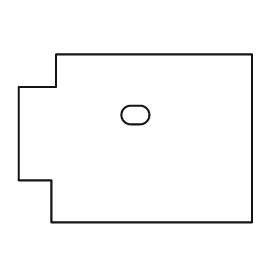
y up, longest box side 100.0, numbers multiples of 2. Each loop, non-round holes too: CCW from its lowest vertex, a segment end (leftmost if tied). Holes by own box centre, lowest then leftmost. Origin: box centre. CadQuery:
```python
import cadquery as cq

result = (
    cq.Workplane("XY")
    .moveTo(-36.0, -36.0)
    .lineTo(50.0, -36.0)
    .lineTo(50.0, 36.0)
    .lineTo(-34.0, 36.0)
    .lineTo(-34.0, 22.0)
    .lineTo(-50.0, 22.0)
    .lineTo(-50.0, -18.0)
    .lineTo(-36.0, -18.0)
    .close()
    .moveTo(-2.0, 6.0)
    .lineTo(2.0, 6.0)
    .threePointArc((6.0, 10.0), (2.0, 14.0))
    .lineTo(-2.0, 14.0)
    .threePointArc((-6.0, 10.0), (-2.0, 6.0))
    .close()
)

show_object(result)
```